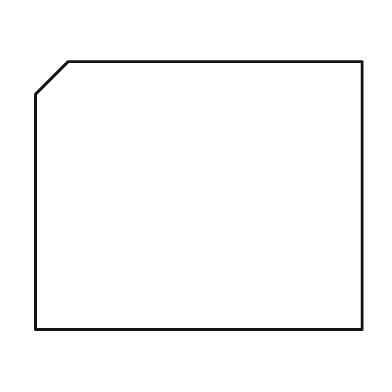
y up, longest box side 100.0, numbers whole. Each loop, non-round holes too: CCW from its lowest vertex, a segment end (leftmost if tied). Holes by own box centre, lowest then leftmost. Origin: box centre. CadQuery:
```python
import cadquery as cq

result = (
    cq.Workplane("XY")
    .moveTo(-50.0, -41.0)
    .lineTo(50.0, -41.0)
    .lineTo(50.0, 41.0)
    .lineTo(-40.0, 41.0)
    .lineTo(-50.0, 31.0)
    .close()
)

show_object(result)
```